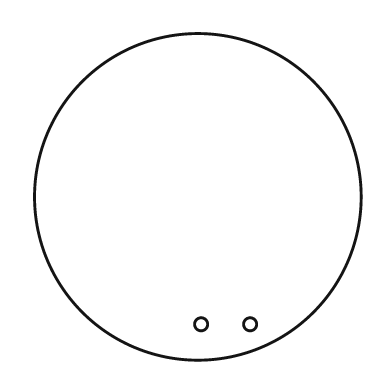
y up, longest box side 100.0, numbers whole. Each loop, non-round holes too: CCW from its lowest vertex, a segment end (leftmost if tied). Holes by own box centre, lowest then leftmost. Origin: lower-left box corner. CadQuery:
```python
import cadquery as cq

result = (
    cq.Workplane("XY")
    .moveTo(50.0, 50.0)
    .circle(50.0)
    .moveTo(51.0, 11.0)
    .circle(2.0)
    .moveTo(66.0, 11.0)
    .circle(2.0)
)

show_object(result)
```